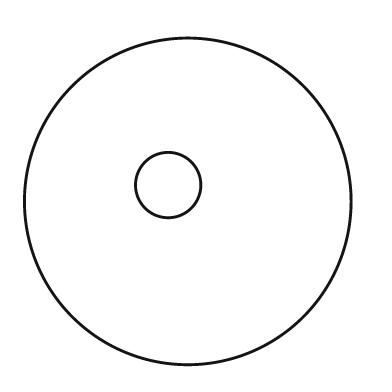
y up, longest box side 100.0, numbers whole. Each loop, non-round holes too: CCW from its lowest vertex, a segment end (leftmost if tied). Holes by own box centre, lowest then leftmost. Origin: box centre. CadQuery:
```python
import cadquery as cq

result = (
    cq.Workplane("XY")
    .moveTo(0.0, 0.0)
    .circle(50.0)
    .moveTo(-6.0, 5.0)
    .circle(10.0)
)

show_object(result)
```